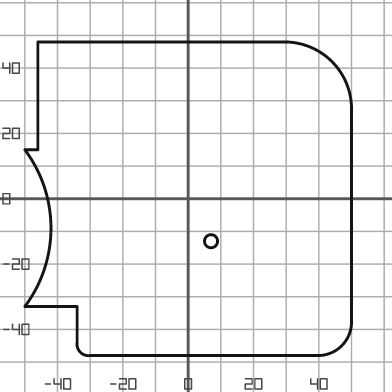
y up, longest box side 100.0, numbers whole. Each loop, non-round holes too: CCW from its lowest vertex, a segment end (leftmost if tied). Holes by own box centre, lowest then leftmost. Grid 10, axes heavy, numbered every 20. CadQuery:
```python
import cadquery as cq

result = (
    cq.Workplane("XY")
    .moveTo(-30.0, -48.0)
    .lineTo(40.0, -48.0)
    .threePointArc((47.0, -45.0), (50.0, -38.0))
    .lineTo(50.0, 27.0)
    .threePointArc((44.0, 42.0), (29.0, 48.0))
    .lineTo(-46.0, 48.0)
    .lineTo(-46.0, 15.0)
    .lineTo(-50.0, 15.0)
    .threePointArc((-42.0, -9.0), (-50.0, -33.0))
    .lineTo(-34.0, -33.0)
    .lineTo(-34.0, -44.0)
    .threePointArc((-33.0, -47.0), (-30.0, -48.0))
    .close()
    .moveTo(7.0, -13.0)
    .circle(2.0)
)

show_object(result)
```